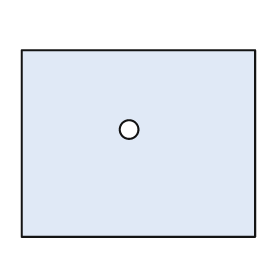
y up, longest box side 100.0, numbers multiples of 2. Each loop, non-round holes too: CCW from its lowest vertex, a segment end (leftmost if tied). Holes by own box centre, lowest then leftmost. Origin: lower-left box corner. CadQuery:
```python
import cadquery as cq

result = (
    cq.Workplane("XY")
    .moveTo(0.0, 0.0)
    .lineTo(100.0, 0.0)
    .lineTo(100.0, 80.0)
    .lineTo(0.0, 80.0)
    .close()
    .moveTo(46.0, 46.0)
    .circle(4.0)
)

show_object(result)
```